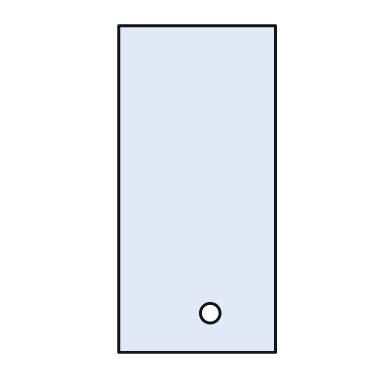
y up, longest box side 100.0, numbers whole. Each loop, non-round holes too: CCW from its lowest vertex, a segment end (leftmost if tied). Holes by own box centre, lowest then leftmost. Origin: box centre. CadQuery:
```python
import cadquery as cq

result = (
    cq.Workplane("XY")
    .moveTo(-24.0, -50.0)
    .lineTo(24.0, -50.0)
    .lineTo(24.0, 50.0)
    .lineTo(-24.0, 50.0)
    .close()
    .moveTo(4.0, -38.0)
    .circle(3.0)
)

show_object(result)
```